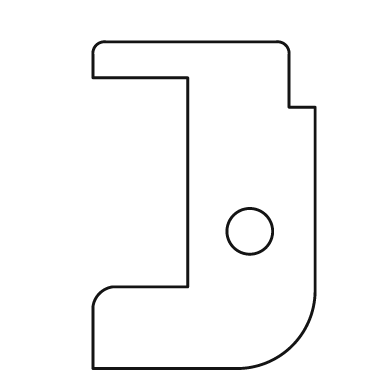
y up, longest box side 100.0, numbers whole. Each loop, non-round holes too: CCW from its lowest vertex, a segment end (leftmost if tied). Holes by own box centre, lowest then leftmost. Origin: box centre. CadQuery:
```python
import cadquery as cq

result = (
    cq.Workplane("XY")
    .moveTo(-34.0, -50.0)
    .lineTo(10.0, -50.0)
    .threePointArc((27.0, -43.0), (34.0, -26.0))
    .lineTo(34.0, 30.0)
    .lineTo(26.0, 30.0)
    .lineTo(26.0, 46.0)
    .threePointArc((25.0, 49.0), (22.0, 50.0))
    .lineTo(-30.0, 50.0)
    .threePointArc((-33.0, 49.0), (-34.0, 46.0))
    .lineTo(-34.0, 39.0)
    .lineTo(-5.0, 39.0)
    .lineTo(-5.0, -25.0)
    .lineTo(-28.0, -25.0)
    .threePointArc((-32.0, -27.0), (-34.0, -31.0))
    .close()
    .moveTo(14.0, -8.0)
    .circle(7.0)
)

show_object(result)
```